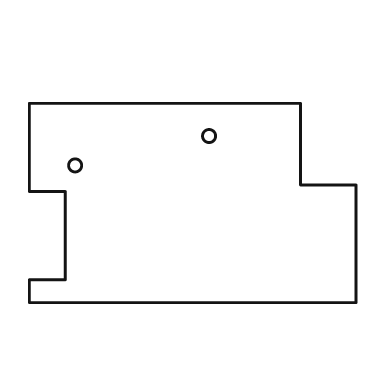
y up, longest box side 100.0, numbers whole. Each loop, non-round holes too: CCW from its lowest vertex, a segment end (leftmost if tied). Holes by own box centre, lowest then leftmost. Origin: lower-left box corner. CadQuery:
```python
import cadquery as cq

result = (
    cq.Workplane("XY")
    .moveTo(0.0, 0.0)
    .lineTo(100.0, 0.0)
    .lineTo(100.0, 36.0)
    .lineTo(83.0, 36.0)
    .lineTo(83.0, 61.0)
    .lineTo(0.0, 61.0)
    .lineTo(0.0, 34.0)
    .lineTo(11.0, 34.0)
    .lineTo(11.0, 7.0)
    .lineTo(0.0, 7.0)
    .close()
    .moveTo(14.0, 42.0)
    .circle(2.0)
    .moveTo(55.0, 51.0)
    .circle(2.0)
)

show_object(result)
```